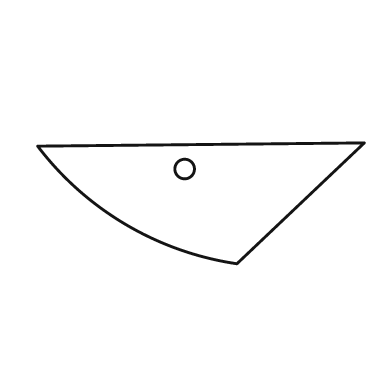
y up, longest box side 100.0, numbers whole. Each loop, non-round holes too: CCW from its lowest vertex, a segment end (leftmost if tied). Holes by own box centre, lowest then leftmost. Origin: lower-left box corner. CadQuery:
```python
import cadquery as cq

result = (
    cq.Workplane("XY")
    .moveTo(61.0, 0.0)
    .lineTo(100.0, 37.0)
    .lineTo(0.0, 36.0)
    .threePointArc((27.0, 12.0), (61.0, 0.0))
    .close()
    .moveTo(45.0, 29.0)
    .circle(3.0)
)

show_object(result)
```